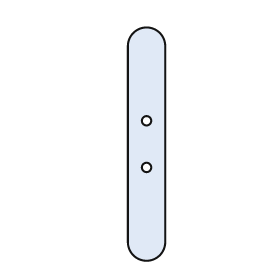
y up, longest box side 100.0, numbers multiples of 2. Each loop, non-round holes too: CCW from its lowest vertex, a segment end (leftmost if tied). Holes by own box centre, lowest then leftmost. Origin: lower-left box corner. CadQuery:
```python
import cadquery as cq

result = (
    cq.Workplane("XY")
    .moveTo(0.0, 8.0)
    .threePointArc((8.0, 0.0), (16.0, 8.0))
    .lineTo(16.0, 92.0)
    .threePointArc((8.0, 100.0), (0.0, 92.0))
    .close()
    .moveTo(8.0, 40.0)
    .circle(2.0)
    .moveTo(8.0, 60.0)
    .circle(2.0)
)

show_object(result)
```